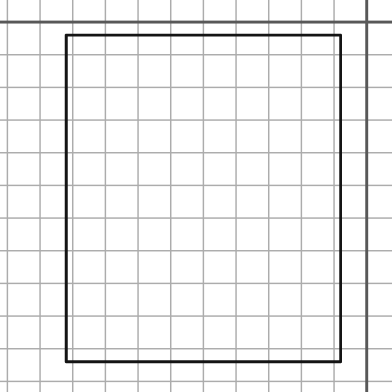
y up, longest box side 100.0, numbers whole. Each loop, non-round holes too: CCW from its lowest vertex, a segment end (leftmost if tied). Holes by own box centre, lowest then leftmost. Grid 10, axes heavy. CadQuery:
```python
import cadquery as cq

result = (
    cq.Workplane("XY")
    .moveTo(-92.0, -104.0)
    .lineTo(-8.0, -104.0)
    .lineTo(-8.0, -4.0)
    .lineTo(-92.0, -4.0)
    .close()
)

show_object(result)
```